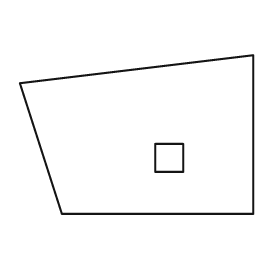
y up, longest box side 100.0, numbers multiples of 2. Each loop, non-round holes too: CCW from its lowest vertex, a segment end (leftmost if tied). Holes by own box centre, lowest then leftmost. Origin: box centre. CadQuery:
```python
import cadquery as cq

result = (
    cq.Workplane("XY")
    .moveTo(-32.0, -34.0)
    .lineTo(50.0, -34.0)
    .lineTo(50.0, 34.0)
    .lineTo(-50.0, 22.0)
    .close()
    .moveTo(8.0, -16.0)
    .lineTo(20.0, -16.0)
    .lineTo(20.0, -4.0)
    .lineTo(8.0, -4.0)
    .close()
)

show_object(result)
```